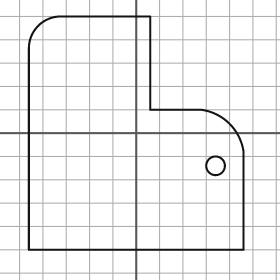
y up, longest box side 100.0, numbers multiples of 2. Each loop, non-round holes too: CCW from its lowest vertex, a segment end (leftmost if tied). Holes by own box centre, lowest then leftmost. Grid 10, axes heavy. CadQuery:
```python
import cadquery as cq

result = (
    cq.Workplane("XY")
    .moveTo(-46.0, -50.0)
    .lineTo(46.0, -50.0)
    .lineTo(46.0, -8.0)
    .threePointArc((40.0, 4.0), (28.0, 10.0))
    .lineTo(6.0, 10.0)
    .lineTo(6.0, 50.0)
    .lineTo(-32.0, 50.0)
    .threePointArc((-42.0, 46.0), (-46.0, 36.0))
    .close()
    .moveTo(34.0, -14.0)
    .circle(4.0)
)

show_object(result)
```